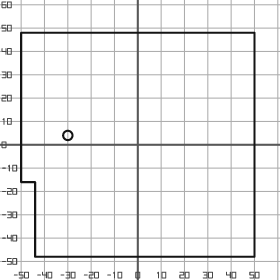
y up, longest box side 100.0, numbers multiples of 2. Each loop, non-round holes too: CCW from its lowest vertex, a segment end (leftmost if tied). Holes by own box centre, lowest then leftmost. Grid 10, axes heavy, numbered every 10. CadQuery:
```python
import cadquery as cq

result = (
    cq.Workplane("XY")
    .moveTo(-44.0, -48.0)
    .lineTo(50.0, -48.0)
    .lineTo(50.0, 48.0)
    .lineTo(-50.0, 48.0)
    .lineTo(-50.0, -16.0)
    .lineTo(-44.0, -16.0)
    .close()
    .moveTo(-30.0, 4.0)
    .circle(2.0)
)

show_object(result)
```